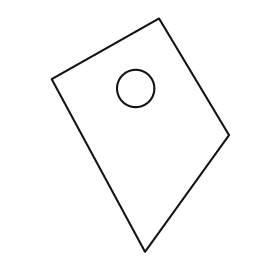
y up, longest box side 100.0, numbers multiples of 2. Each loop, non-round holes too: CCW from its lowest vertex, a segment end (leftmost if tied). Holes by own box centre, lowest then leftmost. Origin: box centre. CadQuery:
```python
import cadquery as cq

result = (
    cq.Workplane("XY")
    .moveTo(2.0, -50.0)
    .lineTo(38.0, 0.0)
    .lineTo(8.0, 50.0)
    .lineTo(-38.0, 24.0)
    .close()
    .moveTo(-2.0, 20.0)
    .circle(8.0)
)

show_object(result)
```